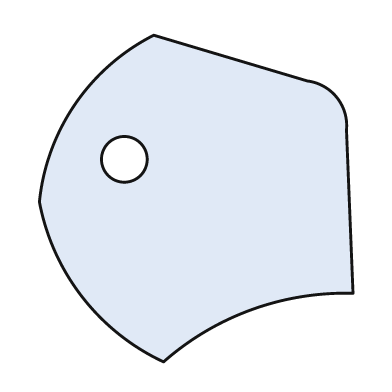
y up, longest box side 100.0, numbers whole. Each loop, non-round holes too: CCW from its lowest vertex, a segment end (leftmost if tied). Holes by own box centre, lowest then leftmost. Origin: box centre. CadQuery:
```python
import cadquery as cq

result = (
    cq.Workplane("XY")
    .moveTo(-10.0, -50.0)
    .threePointArc((17.0, -34.0), (48.0, -29.0))
    .lineTo(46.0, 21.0)
    .threePointArc((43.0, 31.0), (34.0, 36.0))
    .lineTo(-13.0, 50.0)
    .threePointArc((-37.0, 29.0), (-48.0, -1.0))
    .threePointArc((-35.0, -30.0), (-10.0, -50.0))
    .close()
    .moveTo(-22.0, 12.0)
    .circle(7.0)
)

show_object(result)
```